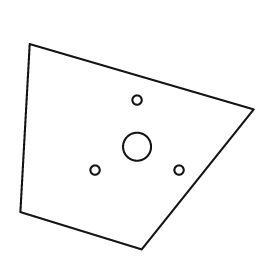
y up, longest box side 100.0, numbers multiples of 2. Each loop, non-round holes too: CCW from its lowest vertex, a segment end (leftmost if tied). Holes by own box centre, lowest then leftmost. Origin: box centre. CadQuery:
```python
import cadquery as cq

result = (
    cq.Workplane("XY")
    .moveTo(2.0, -44.0)
    .lineTo(50.0, 16.0)
    .lineTo(-46.0, 44.0)
    .lineTo(-50.0, -28.0)
    .close()
    .moveTo(-18.0, -10.0)
    .circle(2.0)
    .moveTo(18.0, -10.0)
    .circle(2.0)
    .moveTo(0.0, 0.0)
    .circle(6.0)
    .moveTo(0.0, 20.0)
    .circle(2.0)
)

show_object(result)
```